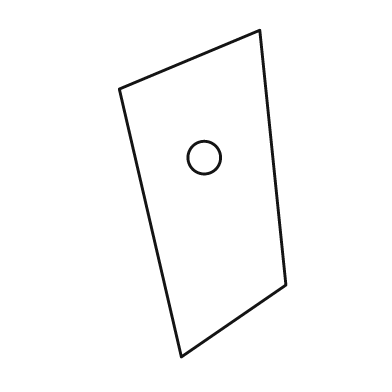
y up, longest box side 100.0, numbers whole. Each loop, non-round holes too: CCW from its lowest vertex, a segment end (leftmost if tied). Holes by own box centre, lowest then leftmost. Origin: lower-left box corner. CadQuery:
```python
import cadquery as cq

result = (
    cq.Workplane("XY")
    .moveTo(19.0, 0.0)
    .lineTo(51.0, 22.0)
    .lineTo(43.0, 100.0)
    .lineTo(0.0, 82.0)
    .close()
    .moveTo(26.0, 61.0)
    .circle(5.0)
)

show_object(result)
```